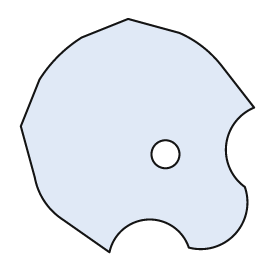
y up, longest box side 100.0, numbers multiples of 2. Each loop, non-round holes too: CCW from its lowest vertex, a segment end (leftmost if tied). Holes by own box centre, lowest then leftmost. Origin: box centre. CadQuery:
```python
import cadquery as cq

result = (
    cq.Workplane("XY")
    .moveTo(-12.0, -50.0)
    .threePointArc((4.0, -36.0), (22.0, -48.0))
    .threePointArc((42.0, -42.0), (46.0, -22.0))
    .threePointArc((38.0, -4.0), (50.0, 12.0))
    .lineTo(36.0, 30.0)
    .threePointArc((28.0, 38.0), (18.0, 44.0))
    .lineTo(-4.0, 50.0)
    .lineTo(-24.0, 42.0)
    .threePointArc((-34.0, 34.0), (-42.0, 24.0))
    .lineTo(-50.0, 4.0)
    .lineTo(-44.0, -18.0)
    .threePointArc((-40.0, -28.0), (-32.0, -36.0))
    .close()
    .moveTo(12.0, -8.0)
    .circle(6.0)
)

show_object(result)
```